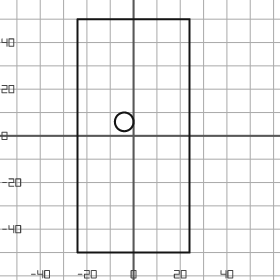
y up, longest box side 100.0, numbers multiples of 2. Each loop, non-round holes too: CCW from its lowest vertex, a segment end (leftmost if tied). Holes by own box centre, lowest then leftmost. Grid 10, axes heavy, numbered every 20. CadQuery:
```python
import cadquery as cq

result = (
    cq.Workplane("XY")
    .moveTo(-24.0, -50.0)
    .lineTo(24.0, -50.0)
    .lineTo(24.0, 50.0)
    .lineTo(-24.0, 50.0)
    .close()
    .moveTo(-4.0, 6.0)
    .circle(4.0)
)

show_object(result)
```